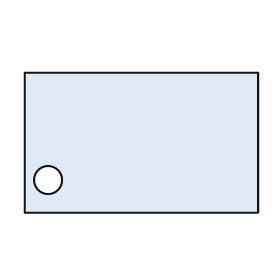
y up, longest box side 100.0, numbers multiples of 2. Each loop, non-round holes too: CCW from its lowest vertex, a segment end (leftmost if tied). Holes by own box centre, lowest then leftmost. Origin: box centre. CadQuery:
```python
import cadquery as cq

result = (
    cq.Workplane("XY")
    .moveTo(-50.0, -30.0)
    .lineTo(50.0, -30.0)
    .lineTo(50.0, 30.0)
    .lineTo(-50.0, 30.0)
    .close()
    .moveTo(-40.0, -16.0)
    .circle(6.0)
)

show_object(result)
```